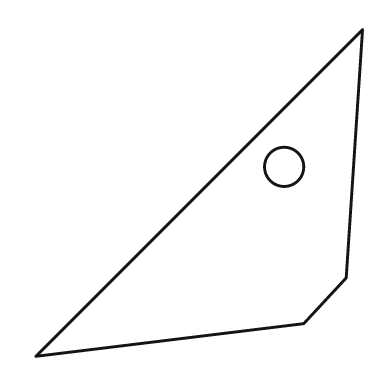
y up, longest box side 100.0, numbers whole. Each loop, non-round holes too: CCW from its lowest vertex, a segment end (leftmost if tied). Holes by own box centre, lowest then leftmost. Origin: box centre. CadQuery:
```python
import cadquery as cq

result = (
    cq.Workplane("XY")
    .moveTo(-50.0, -50.0)
    .lineTo(32.0, -40.0)
    .lineTo(45.0, -26.0)
    .lineTo(50.0, 50.0)
    .close()
    .moveTo(26.0, 8.0)
    .circle(6.0)
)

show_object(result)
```